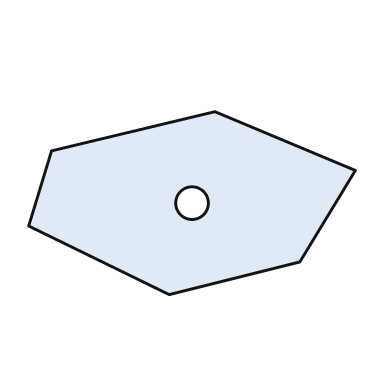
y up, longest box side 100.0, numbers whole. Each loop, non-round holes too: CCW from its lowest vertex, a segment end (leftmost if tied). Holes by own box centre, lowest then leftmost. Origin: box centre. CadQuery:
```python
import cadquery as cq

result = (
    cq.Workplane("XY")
    .moveTo(-7.0, -28.0)
    .lineTo(33.0, -18.0)
    .lineTo(50.0, 10.0)
    .lineTo(7.0, 28.0)
    .lineTo(-43.0, 16.0)
    .lineTo(-50.0, -7.0)
    .close()
    .moveTo(0.0, 0.0)
    .circle(5.0)
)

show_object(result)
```